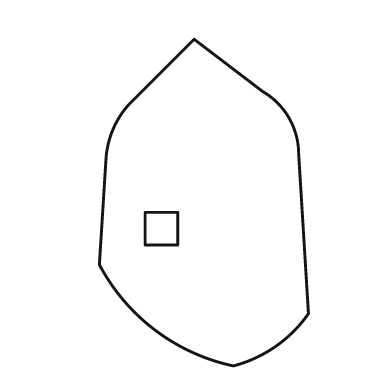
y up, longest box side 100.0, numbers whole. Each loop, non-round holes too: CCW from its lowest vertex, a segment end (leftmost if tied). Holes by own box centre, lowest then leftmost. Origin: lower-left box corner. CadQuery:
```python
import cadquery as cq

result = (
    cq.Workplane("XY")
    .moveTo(41.0, 0.0)
    .threePointArc((54.0, 6.0), (64.0, 16.0))
    .lineTo(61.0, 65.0)
    .threePointArc((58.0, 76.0), (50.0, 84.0))
    .lineTo(29.0, 100.0)
    .lineTo(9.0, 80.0)
    .threePointArc((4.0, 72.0), (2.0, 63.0))
    .lineTo(0.0, 31.0)
    .threePointArc((17.0, 11.0), (41.0, 0.0))
    .close()
    .moveTo(14.0, 37.0)
    .lineTo(24.0, 37.0)
    .lineTo(24.0, 47.0)
    .lineTo(14.0, 47.0)
    .close()
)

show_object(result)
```